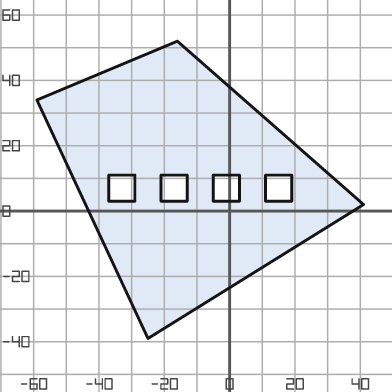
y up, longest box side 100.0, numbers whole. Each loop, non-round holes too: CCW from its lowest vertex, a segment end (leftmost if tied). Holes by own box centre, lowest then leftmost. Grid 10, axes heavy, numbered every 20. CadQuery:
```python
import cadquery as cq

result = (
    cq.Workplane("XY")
    .moveTo(-25.0, -39.0)
    .lineTo(41.0, 2.0)
    .lineTo(-16.0, 52.0)
    .lineTo(-59.0, 34.0)
    .close()
    .moveTo(-37.0, 3.0)
    .lineTo(-29.0, 3.0)
    .lineTo(-29.0, 11.0)
    .lineTo(-37.0, 11.0)
    .close()
    .moveTo(-21.0, 3.0)
    .lineTo(-13.0, 3.0)
    .lineTo(-13.0, 11.0)
    .lineTo(-21.0, 11.0)
    .close()
    .moveTo(-5.0, 3.0)
    .lineTo(3.0, 3.0)
    .lineTo(3.0, 11.0)
    .lineTo(-5.0, 11.0)
    .close()
    .moveTo(11.0, 3.0)
    .lineTo(19.0, 3.0)
    .lineTo(19.0, 11.0)
    .lineTo(11.0, 11.0)
    .close()
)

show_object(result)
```